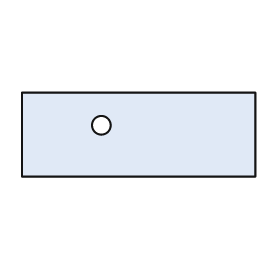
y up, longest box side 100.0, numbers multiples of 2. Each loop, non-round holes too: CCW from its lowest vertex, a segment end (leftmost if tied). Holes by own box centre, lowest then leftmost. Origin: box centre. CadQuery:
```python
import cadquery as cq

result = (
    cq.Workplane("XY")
    .moveTo(-50.0, -18.0)
    .lineTo(50.0, -18.0)
    .lineTo(50.0, 18.0)
    .lineTo(-50.0, 18.0)
    .close()
    .moveTo(-16.0, 4.0)
    .circle(4.0)
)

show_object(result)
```